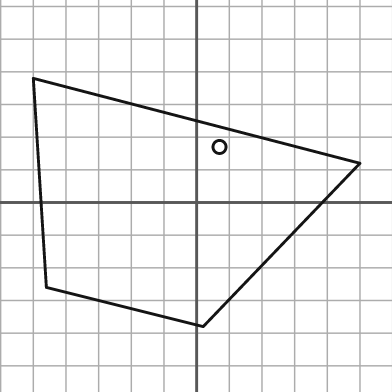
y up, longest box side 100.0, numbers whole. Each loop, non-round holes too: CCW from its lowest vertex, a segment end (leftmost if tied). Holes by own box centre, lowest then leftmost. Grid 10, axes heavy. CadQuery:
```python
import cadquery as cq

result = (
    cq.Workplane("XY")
    .moveTo(2.0, -38.0)
    .lineTo(50.0, 12.0)
    .lineTo(-50.0, 38.0)
    .lineTo(-46.0, -26.0)
    .close()
    .moveTo(7.0, 17.0)
    .circle(2.0)
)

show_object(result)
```